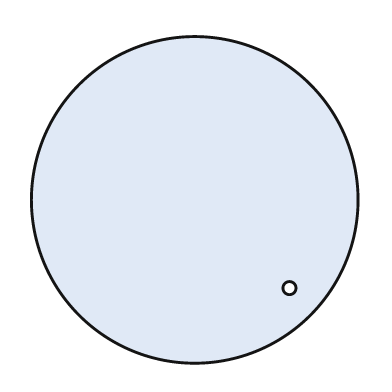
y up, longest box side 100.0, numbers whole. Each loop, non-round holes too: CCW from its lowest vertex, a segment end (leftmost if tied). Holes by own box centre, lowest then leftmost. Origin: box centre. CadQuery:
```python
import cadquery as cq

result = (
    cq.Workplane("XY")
    .moveTo(0.0, 0.0)
    .circle(50.0)
    .moveTo(29.0, -27.0)
    .circle(2.0)
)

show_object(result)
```